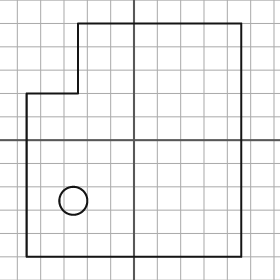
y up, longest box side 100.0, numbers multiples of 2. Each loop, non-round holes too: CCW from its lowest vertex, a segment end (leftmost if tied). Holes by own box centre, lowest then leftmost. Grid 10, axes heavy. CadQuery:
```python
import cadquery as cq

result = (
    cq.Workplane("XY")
    .moveTo(-46.0, -50.0)
    .lineTo(46.0, -50.0)
    .lineTo(46.0, 50.0)
    .lineTo(-24.0, 50.0)
    .lineTo(-24.0, 20.0)
    .lineTo(-46.0, 20.0)
    .close()
    .moveTo(-26.0, -26.0)
    .circle(6.0)
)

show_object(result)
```